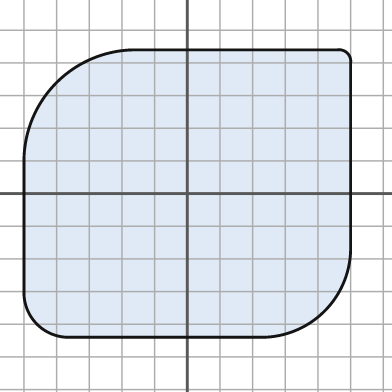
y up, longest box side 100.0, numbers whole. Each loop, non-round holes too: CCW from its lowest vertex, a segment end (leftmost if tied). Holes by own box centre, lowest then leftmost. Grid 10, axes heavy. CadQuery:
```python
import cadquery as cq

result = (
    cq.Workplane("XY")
    .moveTo(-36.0, -44.0)
    .lineTo(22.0, -44.0)
    .threePointArc((42.0, -36.0), (50.0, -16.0))
    .lineTo(50.0, 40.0)
    .threePointArc((49.0, 43.0), (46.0, 44.0))
    .lineTo(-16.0, 44.0)
    .threePointArc((-40.0, 34.0), (-50.0, 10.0))
    .lineTo(-50.0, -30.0)
    .threePointArc((-46.0, -40.0), (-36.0, -44.0))
    .close()
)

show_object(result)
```